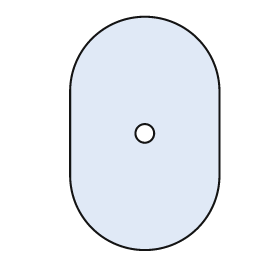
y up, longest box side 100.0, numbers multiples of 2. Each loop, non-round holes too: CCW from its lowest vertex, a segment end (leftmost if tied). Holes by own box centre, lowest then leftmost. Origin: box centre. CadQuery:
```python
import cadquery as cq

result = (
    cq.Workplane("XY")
    .moveTo(-32.0, -18.0)
    .threePointArc((0.0, -50.0), (32.0, -18.0))
    .lineTo(32.0, 18.0)
    .threePointArc((0.0, 50.0), (-32.0, 18.0))
    .close()
    .moveTo(0.0, 0.0)
    .circle(4.0)
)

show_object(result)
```